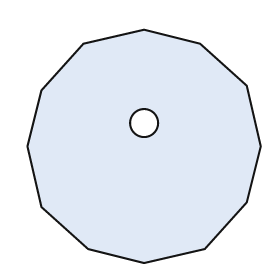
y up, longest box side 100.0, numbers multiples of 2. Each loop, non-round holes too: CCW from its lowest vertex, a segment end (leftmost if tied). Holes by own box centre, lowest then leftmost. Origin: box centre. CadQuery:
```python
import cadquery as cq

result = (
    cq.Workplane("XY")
    .moveTo(0.0, -50.0)
    .lineTo(26.0, -44.0)
    .lineTo(44.0, -24.0)
    .lineTo(50.0, 0.0)
    .lineTo(44.0, 26.0)
    .lineTo(24.0, 44.0)
    .lineTo(0.0, 50.0)
    .lineTo(-26.0, 44.0)
    .lineTo(-44.0, 24.0)
    .lineTo(-50.0, 0.0)
    .lineTo(-44.0, -26.0)
    .lineTo(-24.0, -44.0)
    .close()
    .moveTo(0.0, 10.0)
    .circle(6.0)
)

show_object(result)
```